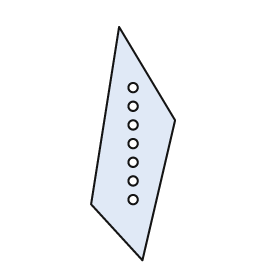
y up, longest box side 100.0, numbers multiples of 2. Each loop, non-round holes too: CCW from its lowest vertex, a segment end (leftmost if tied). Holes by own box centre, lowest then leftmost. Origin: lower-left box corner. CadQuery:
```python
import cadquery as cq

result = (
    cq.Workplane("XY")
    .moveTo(22.0, 0.0)
    .lineTo(36.0, 60.0)
    .lineTo(12.0, 100.0)
    .lineTo(0.0, 24.0)
    .close()
    .moveTo(18.0, 26.0)
    .circle(2.0)
    .moveTo(18.0, 34.0)
    .circle(2.0)
    .moveTo(18.0, 42.0)
    .circle(2.0)
    .moveTo(18.0, 50.0)
    .circle(2.0)
    .moveTo(18.0, 58.0)
    .circle(2.0)
    .moveTo(18.0, 66.0)
    .circle(2.0)
    .moveTo(18.0, 74.0)
    .circle(2.0)
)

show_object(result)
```